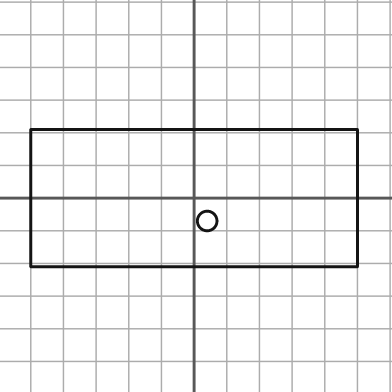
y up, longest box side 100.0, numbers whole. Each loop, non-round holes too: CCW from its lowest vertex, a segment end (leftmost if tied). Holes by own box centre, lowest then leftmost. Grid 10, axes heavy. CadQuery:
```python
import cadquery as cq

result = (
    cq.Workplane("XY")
    .moveTo(-50.0, -21.0)
    .lineTo(50.0, -21.0)
    .lineTo(50.0, 21.0)
    .lineTo(-50.0, 21.0)
    .close()
    .moveTo(4.0, -7.0)
    .circle(3.0)
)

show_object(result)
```